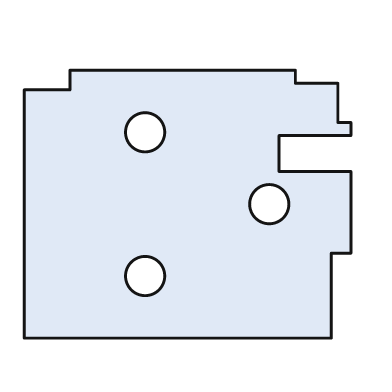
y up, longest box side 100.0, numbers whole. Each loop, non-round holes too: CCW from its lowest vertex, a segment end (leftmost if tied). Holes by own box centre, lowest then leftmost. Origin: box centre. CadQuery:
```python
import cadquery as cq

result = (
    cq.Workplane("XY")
    .moveTo(-50.0, -41.0)
    .lineTo(44.0, -41.0)
    .lineTo(44.0, -15.0)
    .lineTo(50.0, -15.0)
    .lineTo(50.0, 10.0)
    .lineTo(28.0, 10.0)
    .lineTo(28.0, 21.0)
    .lineTo(50.0, 21.0)
    .lineTo(50.0, 25.0)
    .lineTo(46.0, 25.0)
    .lineTo(46.0, 37.0)
    .lineTo(33.0, 37.0)
    .lineTo(33.0, 41.0)
    .lineTo(-36.0, 41.0)
    .lineTo(-36.0, 35.0)
    .lineTo(-50.0, 35.0)
    .close()
    .moveTo(-13.0, -22.0)
    .circle(6.0)
    .moveTo(25.0, 0.0)
    .circle(6.0)
    .moveTo(-13.0, 22.0)
    .circle(6.0)
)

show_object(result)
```